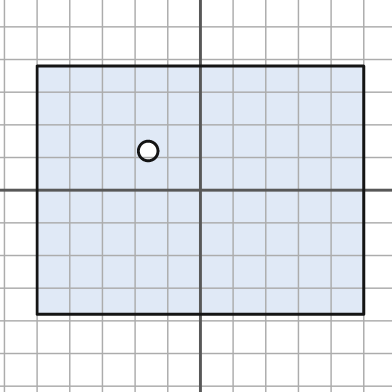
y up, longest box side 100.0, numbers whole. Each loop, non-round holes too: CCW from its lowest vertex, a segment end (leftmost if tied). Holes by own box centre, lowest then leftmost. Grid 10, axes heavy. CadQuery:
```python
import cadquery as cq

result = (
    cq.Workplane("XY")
    .moveTo(-50.0, -38.0)
    .lineTo(50.0, -38.0)
    .lineTo(50.0, 38.0)
    .lineTo(-50.0, 38.0)
    .close()
    .moveTo(-16.0, 12.0)
    .circle(3.0)
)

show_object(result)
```